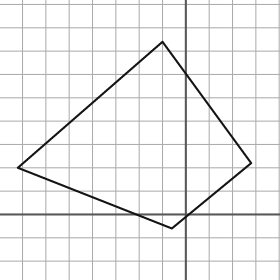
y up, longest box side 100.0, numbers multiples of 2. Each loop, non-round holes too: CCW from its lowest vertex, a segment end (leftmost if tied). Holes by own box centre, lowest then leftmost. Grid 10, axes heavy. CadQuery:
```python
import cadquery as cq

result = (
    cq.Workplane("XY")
    .moveTo(-6.0, -6.0)
    .lineTo(28.0, 22.0)
    .lineTo(-10.0, 74.0)
    .lineTo(-72.0, 20.0)
    .close()
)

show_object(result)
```